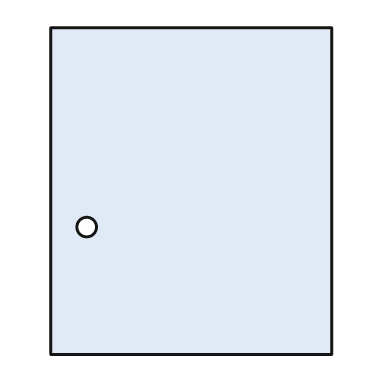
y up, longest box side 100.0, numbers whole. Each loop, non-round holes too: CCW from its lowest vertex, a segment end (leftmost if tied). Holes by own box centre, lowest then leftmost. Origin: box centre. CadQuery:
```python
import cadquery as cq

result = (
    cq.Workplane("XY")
    .moveTo(-43.0, -50.0)
    .lineTo(43.0, -50.0)
    .lineTo(43.0, 50.0)
    .lineTo(-43.0, 50.0)
    .close()
    .moveTo(-32.0, -11.0)
    .circle(3.0)
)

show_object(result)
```